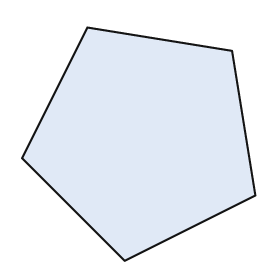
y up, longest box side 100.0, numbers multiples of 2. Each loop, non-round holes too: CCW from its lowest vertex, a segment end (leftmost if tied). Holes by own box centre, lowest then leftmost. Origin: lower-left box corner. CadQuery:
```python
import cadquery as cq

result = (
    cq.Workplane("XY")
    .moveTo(44.0, 0.0)
    .lineTo(100.0, 28.0)
    .lineTo(90.0, 90.0)
    .lineTo(28.0, 100.0)
    .lineTo(0.0, 44.0)
    .close()
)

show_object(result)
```